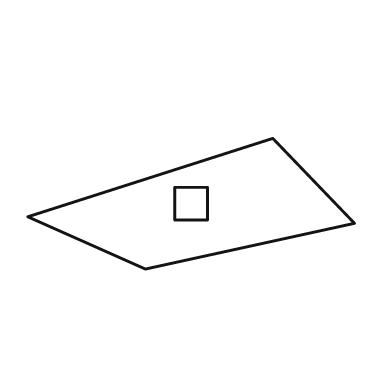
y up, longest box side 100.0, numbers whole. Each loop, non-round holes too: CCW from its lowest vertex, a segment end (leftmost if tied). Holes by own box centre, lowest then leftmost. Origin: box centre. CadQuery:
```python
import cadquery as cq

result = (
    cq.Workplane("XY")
    .moveTo(-14.0, -20.0)
    .lineTo(50.0, -6.0)
    .lineTo(25.0, 20.0)
    .lineTo(-50.0, -4.0)
    .close()
    .moveTo(-5.0, -5.0)
    .lineTo(5.0, -5.0)
    .lineTo(5.0, 5.0)
    .lineTo(-5.0, 5.0)
    .close()
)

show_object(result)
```